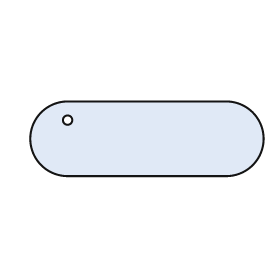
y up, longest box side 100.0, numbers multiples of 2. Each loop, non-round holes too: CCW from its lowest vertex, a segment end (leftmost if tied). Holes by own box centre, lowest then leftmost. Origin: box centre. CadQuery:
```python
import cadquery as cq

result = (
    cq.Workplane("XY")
    .moveTo(-34.0, -16.0)
    .lineTo(34.0, -16.0)
    .threePointArc((50.0, 0.0), (34.0, 16.0))
    .lineTo(-34.0, 16.0)
    .threePointArc((-50.0, 0.0), (-34.0, -16.0))
    .close()
    .moveTo(-34.0, 8.0)
    .circle(2.0)
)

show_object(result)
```